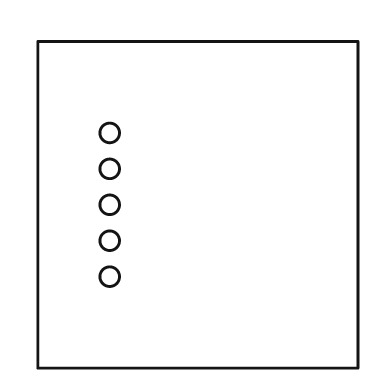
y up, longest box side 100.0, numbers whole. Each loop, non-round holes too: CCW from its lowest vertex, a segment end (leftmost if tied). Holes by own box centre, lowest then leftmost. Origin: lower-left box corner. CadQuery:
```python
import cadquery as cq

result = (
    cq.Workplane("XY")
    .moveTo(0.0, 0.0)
    .lineTo(98.0, 0.0)
    .lineTo(98.0, 100.0)
    .lineTo(0.0, 100.0)
    .close()
    .moveTo(22.0, 28.0)
    .circle(3.0)
    .moveTo(22.0, 39.0)
    .circle(3.0)
    .moveTo(22.0, 50.0)
    .circle(3.0)
    .moveTo(22.0, 61.0)
    .circle(3.0)
    .moveTo(22.0, 72.0)
    .circle(3.0)
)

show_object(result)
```